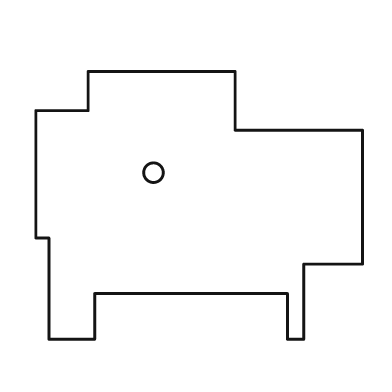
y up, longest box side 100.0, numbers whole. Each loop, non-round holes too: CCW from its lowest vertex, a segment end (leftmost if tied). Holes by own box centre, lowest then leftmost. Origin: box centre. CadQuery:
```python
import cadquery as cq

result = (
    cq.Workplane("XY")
    .moveTo(-46.0, -41.0)
    .lineTo(-32.0, -41.0)
    .lineTo(-32.0, -27.0)
    .lineTo(27.0, -27.0)
    .lineTo(27.0, -41.0)
    .lineTo(32.0, -41.0)
    .lineTo(32.0, -18.0)
    .lineTo(50.0, -18.0)
    .lineTo(50.0, 23.0)
    .lineTo(11.0, 23.0)
    .lineTo(11.0, 41.0)
    .lineTo(-34.0, 41.0)
    .lineTo(-34.0, 29.0)
    .lineTo(-50.0, 29.0)
    .lineTo(-50.0, -10.0)
    .lineTo(-46.0, -10.0)
    .close()
    .moveTo(-14.0, 10.0)
    .circle(3.0)
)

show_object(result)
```